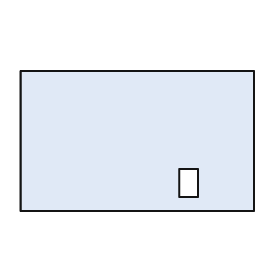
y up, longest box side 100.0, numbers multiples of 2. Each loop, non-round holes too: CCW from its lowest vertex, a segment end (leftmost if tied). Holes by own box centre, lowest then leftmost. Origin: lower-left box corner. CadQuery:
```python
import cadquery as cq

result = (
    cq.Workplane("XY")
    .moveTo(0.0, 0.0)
    .lineTo(100.0, 0.0)
    .lineTo(100.0, 60.0)
    .lineTo(0.0, 60.0)
    .close()
    .moveTo(68.0, 6.0)
    .lineTo(76.0, 6.0)
    .lineTo(76.0, 18.0)
    .lineTo(68.0, 18.0)
    .close()
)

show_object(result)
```